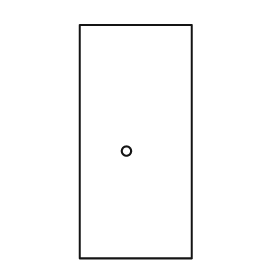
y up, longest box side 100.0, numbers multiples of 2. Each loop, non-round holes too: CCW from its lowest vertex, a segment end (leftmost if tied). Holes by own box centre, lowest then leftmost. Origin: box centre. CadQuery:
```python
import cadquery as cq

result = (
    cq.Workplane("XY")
    .moveTo(-24.0, -50.0)
    .lineTo(24.0, -50.0)
    .lineTo(24.0, 50.0)
    .lineTo(-24.0, 50.0)
    .close()
    .moveTo(-4.0, -4.0)
    .circle(2.0)
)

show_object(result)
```